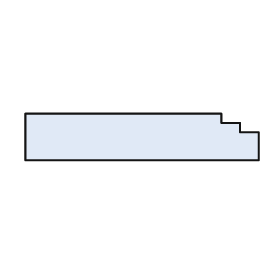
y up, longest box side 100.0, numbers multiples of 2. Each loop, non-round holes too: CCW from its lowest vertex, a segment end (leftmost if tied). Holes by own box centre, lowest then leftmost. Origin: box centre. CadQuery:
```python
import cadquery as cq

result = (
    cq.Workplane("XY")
    .moveTo(-50.0, -10.0)
    .lineTo(50.0, -10.0)
    .lineTo(50.0, 2.0)
    .lineTo(42.0, 2.0)
    .lineTo(42.0, 6.0)
    .lineTo(34.0, 6.0)
    .lineTo(34.0, 10.0)
    .lineTo(-50.0, 10.0)
    .close()
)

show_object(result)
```